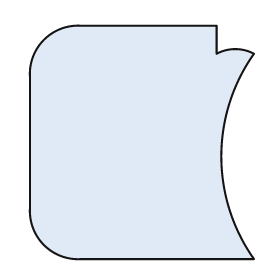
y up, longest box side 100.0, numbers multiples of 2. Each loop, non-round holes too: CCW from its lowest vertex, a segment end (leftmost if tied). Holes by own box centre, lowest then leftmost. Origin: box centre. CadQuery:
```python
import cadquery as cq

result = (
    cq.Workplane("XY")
    .moveTo(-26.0, -50.0)
    .lineTo(48.0, -50.0)
    .threePointArc((34.0, -6.0), (48.0, 38.0))
    .threePointArc((40.0, 40.0), (32.0, 38.0))
    .lineTo(32.0, 50.0)
    .lineTo(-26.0, 50.0)
    .threePointArc((-42.0, 44.0), (-48.0, 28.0))
    .lineTo(-48.0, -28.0)
    .threePointArc((-42.0, -44.0), (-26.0, -50.0))
    .close()
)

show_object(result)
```